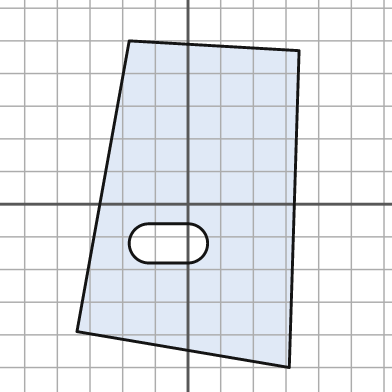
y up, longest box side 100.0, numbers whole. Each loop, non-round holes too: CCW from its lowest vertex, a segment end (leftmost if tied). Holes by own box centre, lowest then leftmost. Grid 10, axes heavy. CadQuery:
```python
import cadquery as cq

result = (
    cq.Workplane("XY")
    .moveTo(31.0, -50.0)
    .lineTo(34.0, 47.0)
    .lineTo(-18.0, 50.0)
    .lineTo(-34.0, -39.0)
    .close()
    .moveTo(-12.0, -18.0)
    .lineTo(0.0, -18.0)
    .threePointArc((6.0, -12.0), (0.0, -6.0))
    .lineTo(-12.0, -6.0)
    .threePointArc((-18.0, -12.0), (-12.0, -18.0))
    .close()
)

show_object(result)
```